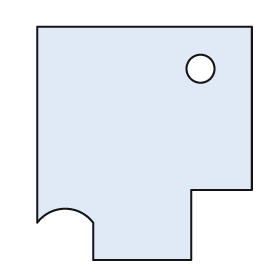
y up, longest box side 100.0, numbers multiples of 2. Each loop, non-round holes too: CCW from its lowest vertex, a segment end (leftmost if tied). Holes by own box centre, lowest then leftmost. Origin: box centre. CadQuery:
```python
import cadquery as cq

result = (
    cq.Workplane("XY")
    .moveTo(-22.0, -50.0)
    .lineTo(20.0, -50.0)
    .lineTo(20.0, -20.0)
    .lineTo(46.0, -20.0)
    .lineTo(46.0, 50.0)
    .lineTo(-46.0, 50.0)
    .lineTo(-46.0, -34.0)
    .threePointArc((-34.0, -28.0), (-22.0, -34.0))
    .close()
    .moveTo(24.0, 32.0)
    .circle(6.0)
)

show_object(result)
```